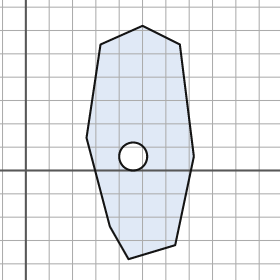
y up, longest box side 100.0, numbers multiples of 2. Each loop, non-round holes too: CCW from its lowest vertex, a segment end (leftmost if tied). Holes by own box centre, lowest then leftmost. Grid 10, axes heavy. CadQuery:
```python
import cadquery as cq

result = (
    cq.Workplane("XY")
    .moveTo(44.0, -38.0)
    .lineTo(64.0, -32.0)
    .lineTo(72.0, 6.0)
    .lineTo(66.0, 54.0)
    .lineTo(50.0, 62.0)
    .lineTo(32.0, 54.0)
    .lineTo(26.0, 14.0)
    .lineTo(36.0, -24.0)
    .close()
    .moveTo(46.0, 6.0)
    .circle(6.0)
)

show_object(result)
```